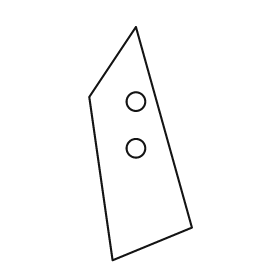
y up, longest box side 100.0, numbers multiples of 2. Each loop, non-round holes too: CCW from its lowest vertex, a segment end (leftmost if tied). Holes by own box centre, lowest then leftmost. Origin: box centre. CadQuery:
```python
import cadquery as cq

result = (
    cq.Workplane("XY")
    .moveTo(-12.0, -50.0)
    .lineTo(22.0, -36.0)
    .lineTo(-2.0, 50.0)
    .lineTo(-22.0, 20.0)
    .close()
    .moveTo(-2.0, -2.0)
    .circle(4.0)
    .moveTo(-2.0, 18.0)
    .circle(4.0)
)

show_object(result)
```